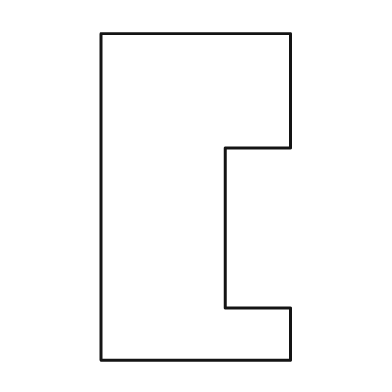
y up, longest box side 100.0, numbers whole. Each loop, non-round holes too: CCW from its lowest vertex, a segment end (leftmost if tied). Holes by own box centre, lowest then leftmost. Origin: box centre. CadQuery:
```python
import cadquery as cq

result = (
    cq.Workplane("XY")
    .moveTo(-29.0, -50.0)
    .lineTo(29.0, -50.0)
    .lineTo(29.0, -34.0)
    .lineTo(9.0, -34.0)
    .lineTo(9.0, 15.0)
    .lineTo(29.0, 15.0)
    .lineTo(29.0, 50.0)
    .lineTo(-29.0, 50.0)
    .close()
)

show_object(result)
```